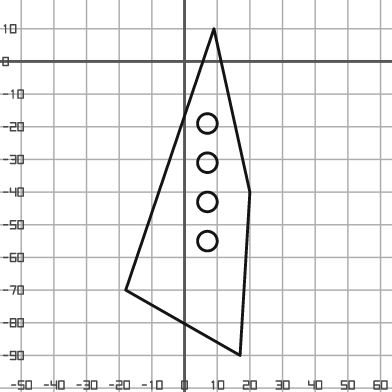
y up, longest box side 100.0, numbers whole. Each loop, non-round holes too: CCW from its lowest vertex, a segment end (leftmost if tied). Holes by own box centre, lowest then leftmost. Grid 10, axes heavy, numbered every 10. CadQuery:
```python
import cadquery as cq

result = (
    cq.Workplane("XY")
    .moveTo(17.0, -90.0)
    .lineTo(20.0, -40.0)
    .lineTo(9.0, 10.0)
    .lineTo(-18.0, -70.0)
    .close()
    .moveTo(7.0, -55.0)
    .circle(3.0)
    .moveTo(7.0, -43.0)
    .circle(3.0)
    .moveTo(7.0, -31.0)
    .circle(3.0)
    .moveTo(7.0, -19.0)
    .circle(3.0)
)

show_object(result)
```